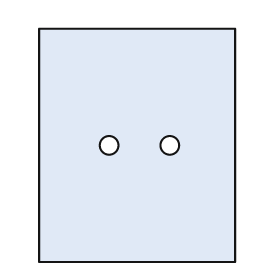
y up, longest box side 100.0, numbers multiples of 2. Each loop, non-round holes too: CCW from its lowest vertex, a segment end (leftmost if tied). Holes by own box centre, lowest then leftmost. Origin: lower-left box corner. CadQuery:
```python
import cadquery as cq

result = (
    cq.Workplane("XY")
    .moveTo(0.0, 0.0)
    .lineTo(84.0, 0.0)
    .lineTo(84.0, 100.0)
    .lineTo(0.0, 100.0)
    .close()
    .moveTo(30.0, 50.0)
    .circle(4.0)
    .moveTo(56.0, 50.0)
    .circle(4.0)
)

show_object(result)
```